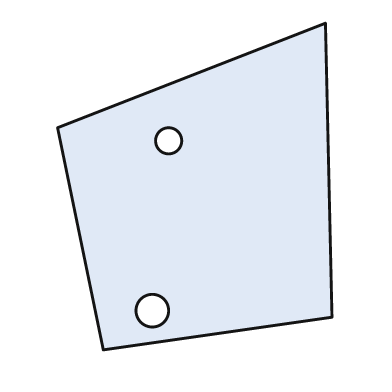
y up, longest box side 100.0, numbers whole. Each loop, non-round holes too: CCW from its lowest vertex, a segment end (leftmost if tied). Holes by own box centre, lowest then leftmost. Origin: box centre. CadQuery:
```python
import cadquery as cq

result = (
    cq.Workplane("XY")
    .moveTo(-28.0, -50.0)
    .lineTo(42.0, -40.0)
    .lineTo(40.0, 50.0)
    .lineTo(-42.0, 18.0)
    .close()
    .moveTo(-13.0, -38.0)
    .circle(5.0)
    .moveTo(-8.0, 14.0)
    .circle(4.0)
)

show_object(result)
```